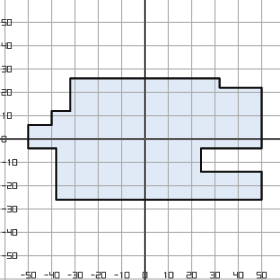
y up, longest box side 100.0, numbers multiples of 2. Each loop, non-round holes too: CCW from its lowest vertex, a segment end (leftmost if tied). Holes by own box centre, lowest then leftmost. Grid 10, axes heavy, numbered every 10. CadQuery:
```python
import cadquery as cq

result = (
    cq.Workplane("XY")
    .moveTo(-38.0, -26.0)
    .lineTo(50.0, -26.0)
    .lineTo(50.0, -14.0)
    .lineTo(24.0, -14.0)
    .lineTo(24.0, -4.0)
    .lineTo(50.0, -4.0)
    .lineTo(50.0, 22.0)
    .lineTo(32.0, 22.0)
    .lineTo(32.0, 26.0)
    .lineTo(-32.0, 26.0)
    .lineTo(-32.0, 12.0)
    .lineTo(-40.0, 12.0)
    .lineTo(-40.0, 6.0)
    .lineTo(-50.0, 6.0)
    .lineTo(-50.0, -4.0)
    .lineTo(-38.0, -4.0)
    .close()
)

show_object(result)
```